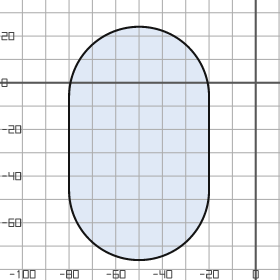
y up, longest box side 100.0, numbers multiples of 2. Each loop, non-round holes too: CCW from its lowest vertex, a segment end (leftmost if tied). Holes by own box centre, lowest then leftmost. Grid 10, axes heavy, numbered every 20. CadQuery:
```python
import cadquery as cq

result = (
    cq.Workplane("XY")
    .moveTo(-80.0, -46.0)
    .threePointArc((-50.0, -76.0), (-20.0, -46.0))
    .lineTo(-20.0, -6.0)
    .threePointArc((-50.0, 24.0), (-80.0, -6.0))
    .close()
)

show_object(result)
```